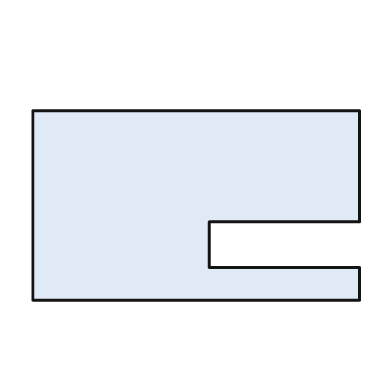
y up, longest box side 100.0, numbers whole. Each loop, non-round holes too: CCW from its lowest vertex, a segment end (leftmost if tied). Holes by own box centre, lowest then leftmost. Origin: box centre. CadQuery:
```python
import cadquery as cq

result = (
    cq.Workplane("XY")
    .moveTo(-50.0, -29.0)
    .lineTo(50.0, -29.0)
    .lineTo(50.0, -19.0)
    .lineTo(4.0, -19.0)
    .lineTo(4.0, -5.0)
    .lineTo(50.0, -5.0)
    .lineTo(50.0, 29.0)
    .lineTo(-50.0, 29.0)
    .close()
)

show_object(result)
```